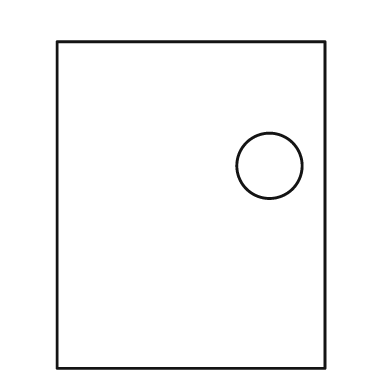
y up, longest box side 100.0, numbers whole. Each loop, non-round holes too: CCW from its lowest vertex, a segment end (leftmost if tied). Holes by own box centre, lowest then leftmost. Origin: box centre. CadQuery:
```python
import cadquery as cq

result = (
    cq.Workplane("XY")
    .moveTo(-41.0, -50.0)
    .lineTo(41.0, -50.0)
    .lineTo(41.0, 50.0)
    .lineTo(-41.0, 50.0)
    .close()
    .moveTo(24.0, 12.0)
    .circle(10.0)
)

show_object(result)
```